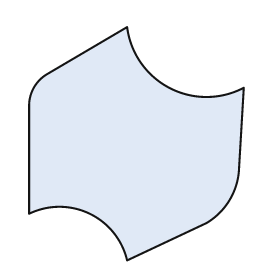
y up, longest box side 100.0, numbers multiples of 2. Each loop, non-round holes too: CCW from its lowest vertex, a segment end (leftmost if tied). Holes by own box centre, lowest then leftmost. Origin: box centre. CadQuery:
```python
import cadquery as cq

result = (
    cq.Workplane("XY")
    .moveTo(-4.0, -50.0)
    .lineTo(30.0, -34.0)
    .threePointArc((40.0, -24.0), (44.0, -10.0))
    .lineTo(46.0, 24.0)
    .threePointArc((14.0, 24.0), (-4.0, 50.0))
    .lineTo(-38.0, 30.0)
    .threePointArc((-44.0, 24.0), (-46.0, 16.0))
    .lineTo(-46.0, -30.0)
    .threePointArc((-20.0, -30.0), (-4.0, -50.0))
    .close()
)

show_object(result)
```